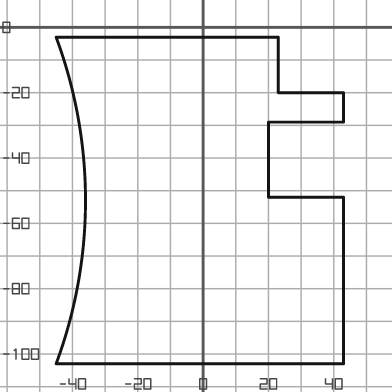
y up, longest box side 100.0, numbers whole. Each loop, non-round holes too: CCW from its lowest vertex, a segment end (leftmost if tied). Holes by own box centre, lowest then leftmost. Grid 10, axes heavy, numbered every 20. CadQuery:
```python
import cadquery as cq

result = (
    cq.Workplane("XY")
    .moveTo(-45.0, -103.0)
    .lineTo(43.0, -103.0)
    .lineTo(43.0, -52.0)
    .lineTo(20.0, -52.0)
    .lineTo(20.0, -29.0)
    .lineTo(43.0, -29.0)
    .lineTo(43.0, -20.0)
    .lineTo(23.0, -20.0)
    .lineTo(23.0, -3.0)
    .lineTo(-45.0, -3.0)
    .threePointArc((-36.0, -53.0), (-45.0, -103.0))
    .close()
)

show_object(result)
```